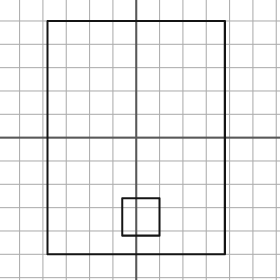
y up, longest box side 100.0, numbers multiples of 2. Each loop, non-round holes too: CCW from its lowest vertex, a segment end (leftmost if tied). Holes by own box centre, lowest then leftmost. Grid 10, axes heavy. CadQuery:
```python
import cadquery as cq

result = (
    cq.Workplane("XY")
    .moveTo(-38.0, -50.0)
    .lineTo(38.0, -50.0)
    .lineTo(38.0, 50.0)
    .lineTo(-38.0, 50.0)
    .close()
    .moveTo(-6.0, -42.0)
    .lineTo(10.0, -42.0)
    .lineTo(10.0, -26.0)
    .lineTo(-6.0, -26.0)
    .close()
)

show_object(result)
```